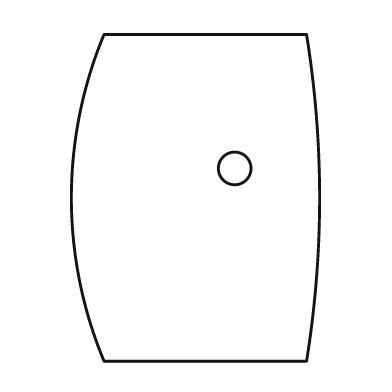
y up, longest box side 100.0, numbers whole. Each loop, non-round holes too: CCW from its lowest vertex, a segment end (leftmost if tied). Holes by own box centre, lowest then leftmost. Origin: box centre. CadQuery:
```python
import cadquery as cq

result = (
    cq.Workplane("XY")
    .moveTo(-28.0, -50.0)
    .lineTo(34.0, -50.0)
    .threePointArc((38.0, 0.0), (34.0, 50.0))
    .lineTo(-28.0, 50.0)
    .threePointArc((-38.0, 0.0), (-28.0, -50.0))
    .close()
    .moveTo(12.0, 9.0)
    .circle(5.0)
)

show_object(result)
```